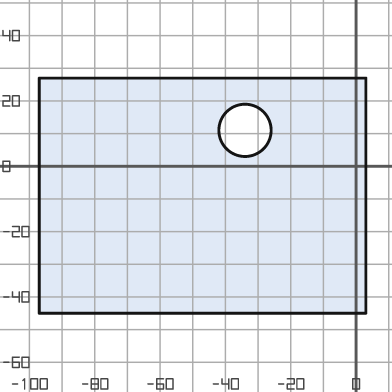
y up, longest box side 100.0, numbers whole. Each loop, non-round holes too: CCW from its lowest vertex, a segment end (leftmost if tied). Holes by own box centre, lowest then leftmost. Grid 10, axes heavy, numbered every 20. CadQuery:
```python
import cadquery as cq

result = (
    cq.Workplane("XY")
    .moveTo(-97.0, -45.0)
    .lineTo(3.0, -45.0)
    .lineTo(3.0, 27.0)
    .lineTo(-97.0, 27.0)
    .close()
    .moveTo(-34.0, 11.0)
    .circle(8.0)
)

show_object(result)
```